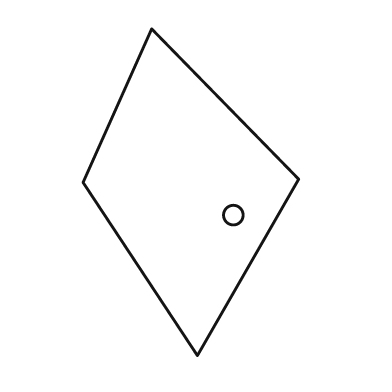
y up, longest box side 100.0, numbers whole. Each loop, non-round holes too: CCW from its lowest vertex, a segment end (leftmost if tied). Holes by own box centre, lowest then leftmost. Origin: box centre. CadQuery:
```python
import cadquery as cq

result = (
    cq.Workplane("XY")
    .moveTo(2.0, -50.0)
    .lineTo(33.0, 4.0)
    .lineTo(-12.0, 50.0)
    .lineTo(-33.0, 3.0)
    .close()
    .moveTo(13.0, -7.0)
    .circle(3.0)
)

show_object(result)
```